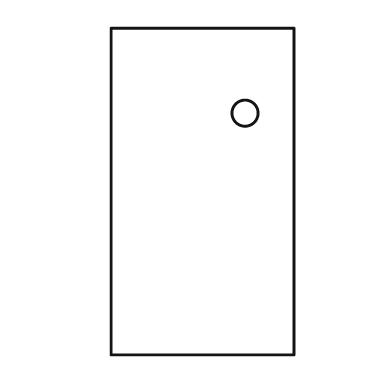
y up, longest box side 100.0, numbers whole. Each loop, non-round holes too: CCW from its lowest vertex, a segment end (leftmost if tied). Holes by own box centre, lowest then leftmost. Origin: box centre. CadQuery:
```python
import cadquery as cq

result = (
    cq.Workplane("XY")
    .moveTo(-28.0, -50.0)
    .lineTo(28.0, -50.0)
    .lineTo(28.0, 50.0)
    .lineTo(-28.0, 50.0)
    .close()
    .moveTo(13.0, 24.0)
    .circle(4.0)
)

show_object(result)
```